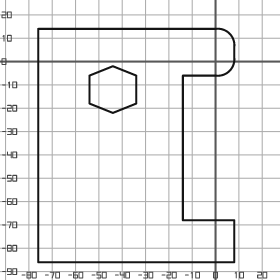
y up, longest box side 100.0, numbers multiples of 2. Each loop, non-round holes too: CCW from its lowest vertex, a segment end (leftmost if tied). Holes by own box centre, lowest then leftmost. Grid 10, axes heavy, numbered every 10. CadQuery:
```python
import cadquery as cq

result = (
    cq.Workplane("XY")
    .moveTo(-76.0, -86.0)
    .lineTo(8.0, -86.0)
    .lineTo(8.0, -68.0)
    .lineTo(-14.0, -68.0)
    .lineTo(-14.0, -6.0)
    .lineTo(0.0, -6.0)
    .threePointArc((6.0, -4.0), (8.0, 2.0))
    .lineTo(8.0, 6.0)
    .threePointArc((6.0, 12.0), (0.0, 14.0))
    .lineTo(-76.0, 14.0)
    .close()
    .moveTo(-44.0, -22.0)
    .lineTo(-34.0, -18.0)
    .lineTo(-34.0, -6.0)
    .lineTo(-44.0, -2.0)
    .lineTo(-54.0, -6.0)
    .lineTo(-54.0, -18.0)
    .close()
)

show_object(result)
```